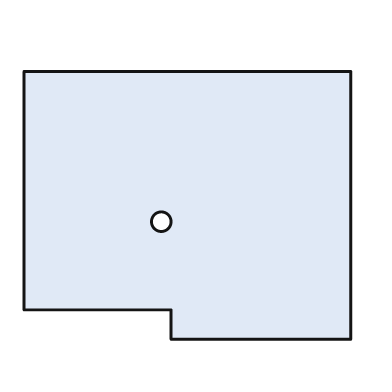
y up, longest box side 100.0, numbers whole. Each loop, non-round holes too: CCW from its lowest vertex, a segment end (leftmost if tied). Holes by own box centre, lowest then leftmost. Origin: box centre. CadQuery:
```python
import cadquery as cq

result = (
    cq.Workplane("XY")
    .moveTo(-5.0, -41.0)
    .lineTo(50.0, -41.0)
    .lineTo(50.0, 41.0)
    .lineTo(-50.0, 41.0)
    .lineTo(-50.0, -32.0)
    .lineTo(-5.0, -32.0)
    .close()
    .moveTo(-8.0, -5.0)
    .circle(3.0)
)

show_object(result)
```